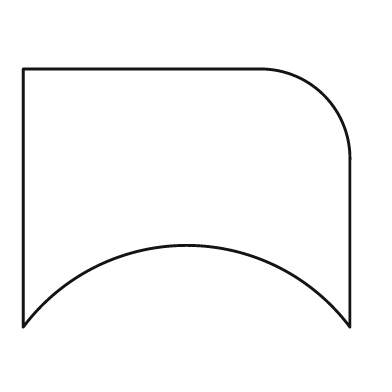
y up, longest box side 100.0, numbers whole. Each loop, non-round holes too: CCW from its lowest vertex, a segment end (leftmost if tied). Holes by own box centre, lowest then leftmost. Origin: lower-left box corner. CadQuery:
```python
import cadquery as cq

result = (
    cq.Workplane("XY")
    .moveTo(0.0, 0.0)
    .threePointArc((50.0, 25.0), (100.0, 0.0))
    .lineTo(100.0, 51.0)
    .threePointArc((92.0, 71.0), (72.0, 79.0))
    .lineTo(0.0, 79.0)
    .close()
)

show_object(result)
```